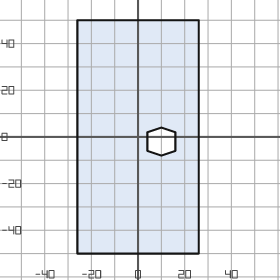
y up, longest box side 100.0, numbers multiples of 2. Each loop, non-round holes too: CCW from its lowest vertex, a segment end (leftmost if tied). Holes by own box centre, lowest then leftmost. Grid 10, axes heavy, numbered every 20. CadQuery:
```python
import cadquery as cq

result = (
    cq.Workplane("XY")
    .moveTo(-26.0, -50.0)
    .lineTo(26.0, -50.0)
    .lineTo(26.0, 50.0)
    .lineTo(-26.0, 50.0)
    .close()
    .moveTo(10.0, -8.0)
    .lineTo(16.0, -6.0)
    .lineTo(16.0, 2.0)
    .lineTo(10.0, 4.0)
    .lineTo(4.0, 2.0)
    .lineTo(4.0, -6.0)
    .close()
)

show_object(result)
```